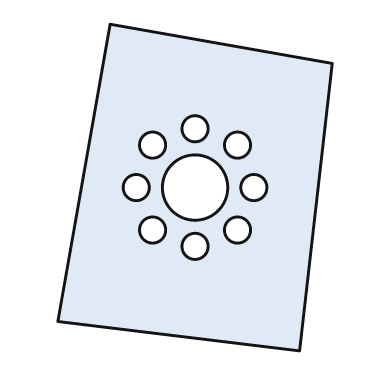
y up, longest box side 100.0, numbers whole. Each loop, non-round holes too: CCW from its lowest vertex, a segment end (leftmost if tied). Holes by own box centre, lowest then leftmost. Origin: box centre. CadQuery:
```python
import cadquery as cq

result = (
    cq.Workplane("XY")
    .moveTo(32.0, -50.0)
    .lineTo(42.0, 38.0)
    .lineTo(-26.0, 50.0)
    .lineTo(-42.0, -41.0)
    .close()
    .moveTo(0.0, -18.0)
    .circle(4.0)
    .moveTo(-13.0, -13.0)
    .circle(4.0)
    .moveTo(13.0, -13.0)
    .circle(4.0)
    .moveTo(-18.0, 0.0)
    .circle(4.0)
    .moveTo(0.0, 0.0)
    .circle(10.0)
    .moveTo(18.0, 0.0)
    .circle(4.0)
    .moveTo(-13.0, 13.0)
    .circle(4.0)
    .moveTo(13.0, 13.0)
    .circle(4.0)
    .moveTo(0.0, 18.0)
    .circle(4.0)
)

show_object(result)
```